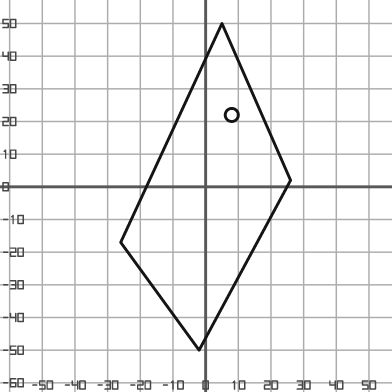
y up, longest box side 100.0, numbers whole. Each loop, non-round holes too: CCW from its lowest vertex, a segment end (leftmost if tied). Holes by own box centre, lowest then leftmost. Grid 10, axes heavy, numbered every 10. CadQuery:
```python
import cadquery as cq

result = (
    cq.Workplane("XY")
    .moveTo(-2.0, -50.0)
    .lineTo(26.0, 2.0)
    .lineTo(5.0, 50.0)
    .lineTo(-26.0, -17.0)
    .close()
    .moveTo(8.0, 22.0)
    .circle(2.0)
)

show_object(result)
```